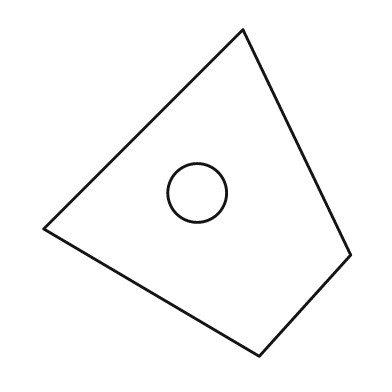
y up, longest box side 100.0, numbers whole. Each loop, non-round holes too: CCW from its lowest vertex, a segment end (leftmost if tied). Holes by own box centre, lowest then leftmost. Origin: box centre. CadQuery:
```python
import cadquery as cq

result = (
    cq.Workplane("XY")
    .moveTo(19.0, -50.0)
    .lineTo(47.0, -19.0)
    .lineTo(14.0, 50.0)
    .lineTo(-47.0, -11.0)
    .close()
    .moveTo(0.0, 0.0)
    .circle(9.0)
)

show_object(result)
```